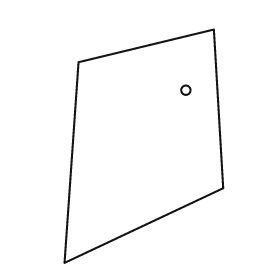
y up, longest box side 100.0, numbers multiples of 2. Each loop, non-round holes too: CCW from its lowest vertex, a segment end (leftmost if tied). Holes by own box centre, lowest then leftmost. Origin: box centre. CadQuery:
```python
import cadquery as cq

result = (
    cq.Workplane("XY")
    .moveTo(-34.0, -50.0)
    .lineTo(34.0, -18.0)
    .lineTo(30.0, 50.0)
    .lineTo(-28.0, 36.0)
    .close()
    .moveTo(18.0, 24.0)
    .circle(2.0)
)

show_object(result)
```